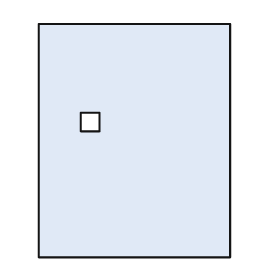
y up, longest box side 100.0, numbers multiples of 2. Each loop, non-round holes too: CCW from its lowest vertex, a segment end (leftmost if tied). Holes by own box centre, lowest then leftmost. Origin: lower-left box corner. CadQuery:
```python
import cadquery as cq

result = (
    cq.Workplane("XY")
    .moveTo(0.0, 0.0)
    .lineTo(82.0, 0.0)
    .lineTo(82.0, 100.0)
    .lineTo(0.0, 100.0)
    .close()
    .moveTo(18.0, 54.0)
    .lineTo(26.0, 54.0)
    .lineTo(26.0, 62.0)
    .lineTo(18.0, 62.0)
    .close()
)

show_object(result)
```